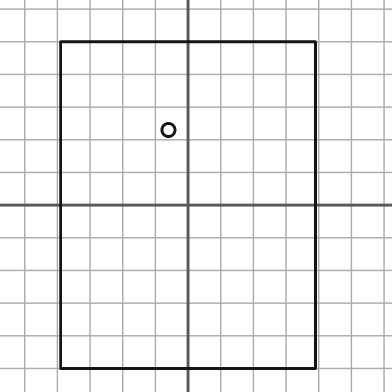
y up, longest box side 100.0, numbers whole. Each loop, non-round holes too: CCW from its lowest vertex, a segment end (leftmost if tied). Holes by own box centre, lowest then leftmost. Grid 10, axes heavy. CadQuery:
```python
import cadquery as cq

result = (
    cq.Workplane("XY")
    .moveTo(-39.0, -50.0)
    .lineTo(39.0, -50.0)
    .lineTo(39.0, 50.0)
    .lineTo(-39.0, 50.0)
    .close()
    .moveTo(-6.0, 23.0)
    .circle(2.0)
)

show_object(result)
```